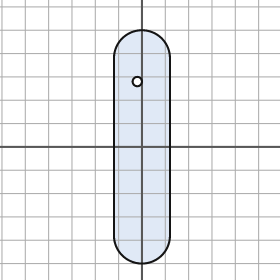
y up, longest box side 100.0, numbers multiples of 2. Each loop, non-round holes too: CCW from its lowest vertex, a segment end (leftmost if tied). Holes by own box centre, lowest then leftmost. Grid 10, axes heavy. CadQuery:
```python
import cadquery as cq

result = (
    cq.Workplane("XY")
    .moveTo(-12.0, -38.0)
    .threePointArc((0.0, -50.0), (12.0, -38.0))
    .lineTo(12.0, 38.0)
    .threePointArc((0.0, 50.0), (-12.0, 38.0))
    .close()
    .moveTo(-2.0, 28.0)
    .circle(2.0)
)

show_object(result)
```